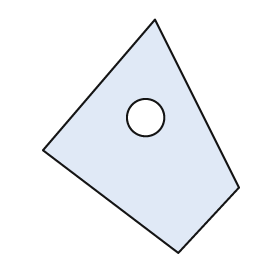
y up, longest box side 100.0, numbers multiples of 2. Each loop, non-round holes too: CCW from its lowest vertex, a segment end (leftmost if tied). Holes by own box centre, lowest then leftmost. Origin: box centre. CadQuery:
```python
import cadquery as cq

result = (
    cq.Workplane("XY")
    .moveTo(16.0, -50.0)
    .lineTo(42.0, -22.0)
    .lineTo(6.0, 50.0)
    .lineTo(-42.0, -6.0)
    .close()
    .moveTo(2.0, 8.0)
    .circle(8.0)
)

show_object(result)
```